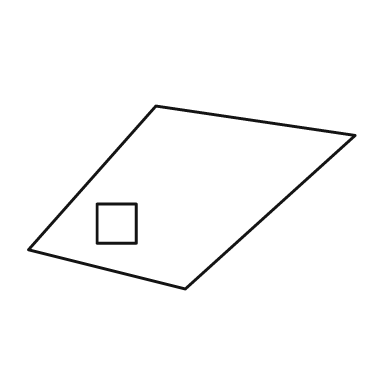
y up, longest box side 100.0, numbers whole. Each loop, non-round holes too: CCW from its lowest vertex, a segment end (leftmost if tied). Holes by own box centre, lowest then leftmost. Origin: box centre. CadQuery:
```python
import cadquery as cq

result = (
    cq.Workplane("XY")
    .moveTo(-2.0, -28.0)
    .lineTo(50.0, 19.0)
    .lineTo(-11.0, 28.0)
    .lineTo(-50.0, -16.0)
    .close()
    .moveTo(-29.0, -14.0)
    .lineTo(-17.0, -14.0)
    .lineTo(-17.0, -2.0)
    .lineTo(-29.0, -2.0)
    .close()
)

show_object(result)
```